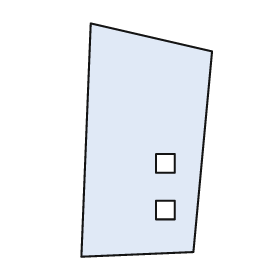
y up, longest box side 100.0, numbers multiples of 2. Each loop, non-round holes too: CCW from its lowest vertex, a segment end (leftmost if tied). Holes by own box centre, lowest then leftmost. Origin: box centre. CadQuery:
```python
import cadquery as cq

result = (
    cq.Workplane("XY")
    .moveTo(-28.0, -50.0)
    .lineTo(20.0, -48.0)
    .lineTo(28.0, 38.0)
    .lineTo(-24.0, 50.0)
    .close()
    .moveTo(4.0, -34.0)
    .lineTo(12.0, -34.0)
    .lineTo(12.0, -26.0)
    .lineTo(4.0, -26.0)
    .close()
    .moveTo(4.0, -14.0)
    .lineTo(12.0, -14.0)
    .lineTo(12.0, -6.0)
    .lineTo(4.0, -6.0)
    .close()
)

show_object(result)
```